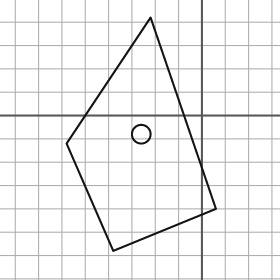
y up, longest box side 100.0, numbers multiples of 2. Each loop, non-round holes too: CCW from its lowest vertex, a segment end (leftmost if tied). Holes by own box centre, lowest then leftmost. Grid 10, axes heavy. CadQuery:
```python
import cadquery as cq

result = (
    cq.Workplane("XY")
    .moveTo(-38.0, -58.0)
    .lineTo(6.0, -40.0)
    .lineTo(-22.0, 42.0)
    .lineTo(-58.0, -12.0)
    .close()
    .moveTo(-26.0, -8.0)
    .circle(4.0)
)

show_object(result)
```